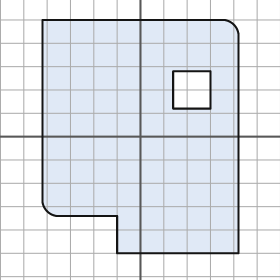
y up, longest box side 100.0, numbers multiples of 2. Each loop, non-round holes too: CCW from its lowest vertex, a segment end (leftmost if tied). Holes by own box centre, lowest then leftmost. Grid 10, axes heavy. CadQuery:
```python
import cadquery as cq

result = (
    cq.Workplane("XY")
    .moveTo(-10.0, -50.0)
    .lineTo(42.0, -50.0)
    .lineTo(42.0, 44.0)
    .threePointArc((40.0, 48.0), (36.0, 50.0))
    .lineTo(-42.0, 50.0)
    .lineTo(-42.0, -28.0)
    .threePointArc((-40.0, -32.0), (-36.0, -34.0))
    .lineTo(-10.0, -34.0)
    .close()
    .moveTo(14.0, 12.0)
    .lineTo(30.0, 12.0)
    .lineTo(30.0, 28.0)
    .lineTo(14.0, 28.0)
    .close()
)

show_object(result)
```